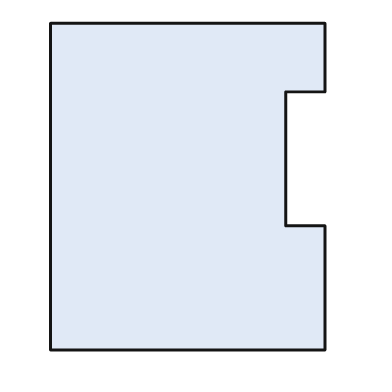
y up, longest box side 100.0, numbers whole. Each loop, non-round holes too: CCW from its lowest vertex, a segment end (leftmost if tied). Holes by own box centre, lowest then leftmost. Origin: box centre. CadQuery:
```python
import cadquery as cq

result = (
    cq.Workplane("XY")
    .moveTo(-42.0, -50.0)
    .lineTo(42.0, -50.0)
    .lineTo(42.0, -12.0)
    .lineTo(30.0, -12.0)
    .lineTo(30.0, 29.0)
    .lineTo(42.0, 29.0)
    .lineTo(42.0, 50.0)
    .lineTo(-42.0, 50.0)
    .close()
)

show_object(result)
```